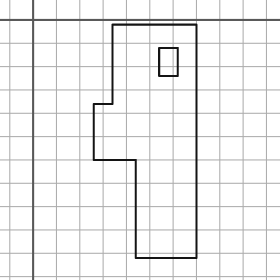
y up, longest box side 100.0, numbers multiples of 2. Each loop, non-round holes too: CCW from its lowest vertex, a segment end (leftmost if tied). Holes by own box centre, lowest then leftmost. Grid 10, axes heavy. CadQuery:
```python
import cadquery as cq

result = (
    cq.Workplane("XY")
    .moveTo(44.0, -102.0)
    .lineTo(70.0, -102.0)
    .lineTo(70.0, -2.0)
    .lineTo(34.0, -2.0)
    .lineTo(34.0, -36.0)
    .lineTo(26.0, -36.0)
    .lineTo(26.0, -60.0)
    .lineTo(44.0, -60.0)
    .close()
    .moveTo(54.0, -24.0)
    .lineTo(62.0, -24.0)
    .lineTo(62.0, -12.0)
    .lineTo(54.0, -12.0)
    .close()
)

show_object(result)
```